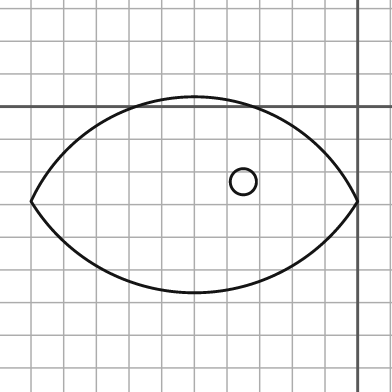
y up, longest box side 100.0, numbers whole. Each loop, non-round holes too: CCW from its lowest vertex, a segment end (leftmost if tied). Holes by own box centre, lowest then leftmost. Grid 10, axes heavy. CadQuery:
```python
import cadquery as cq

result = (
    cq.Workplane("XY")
    .moveTo(-100.0, -29.0)
    .threePointArc((-50.0, -57.0), (0.0, -29.0))
    .threePointArc((-50.0, 3.0), (-100.0, -29.0))
    .close()
    .moveTo(-35.0, -23.0)
    .circle(4.0)
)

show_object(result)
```